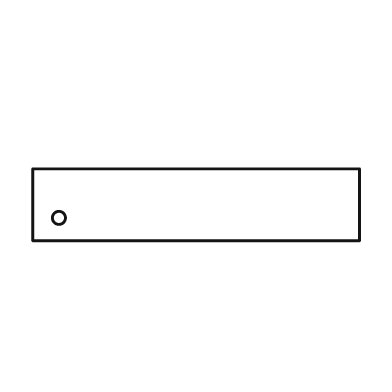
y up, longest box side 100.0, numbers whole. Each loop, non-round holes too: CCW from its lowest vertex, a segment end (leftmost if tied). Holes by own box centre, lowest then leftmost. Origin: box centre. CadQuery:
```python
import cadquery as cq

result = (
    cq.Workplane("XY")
    .moveTo(-50.0, -11.0)
    .lineTo(50.0, -11.0)
    .lineTo(50.0, 11.0)
    .lineTo(-50.0, 11.0)
    .close()
    .moveTo(-42.0, -4.0)
    .circle(2.0)
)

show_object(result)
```